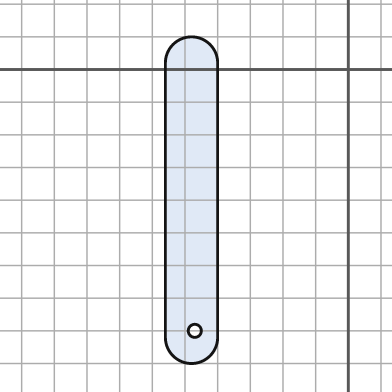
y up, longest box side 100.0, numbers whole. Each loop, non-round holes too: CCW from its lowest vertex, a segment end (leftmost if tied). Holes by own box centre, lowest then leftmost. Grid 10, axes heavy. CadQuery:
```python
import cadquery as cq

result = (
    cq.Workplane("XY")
    .moveTo(-56.0, -82.0)
    .threePointArc((-48.0, -90.0), (-40.0, -82.0))
    .lineTo(-40.0, 2.0)
    .threePointArc((-48.0, 10.0), (-56.0, 2.0))
    .close()
    .moveTo(-47.0, -80.0)
    .circle(2.0)
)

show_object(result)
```